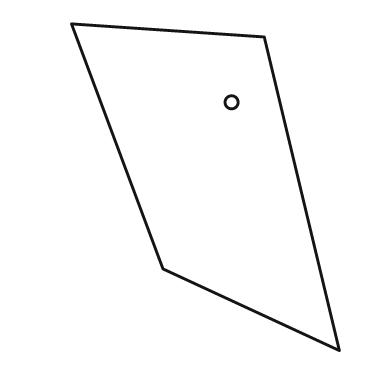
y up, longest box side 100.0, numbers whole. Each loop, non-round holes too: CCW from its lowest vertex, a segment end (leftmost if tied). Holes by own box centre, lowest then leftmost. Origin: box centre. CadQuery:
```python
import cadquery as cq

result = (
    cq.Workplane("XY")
    .moveTo(41.0, -50.0)
    .lineTo(18.0, 46.0)
    .lineTo(-41.0, 50.0)
    .lineTo(-13.0, -25.0)
    .close()
    .moveTo(8.0, 26.0)
    .circle(2.0)
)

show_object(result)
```